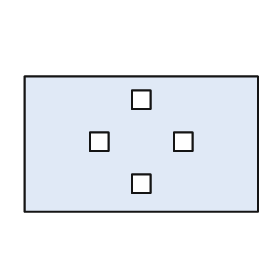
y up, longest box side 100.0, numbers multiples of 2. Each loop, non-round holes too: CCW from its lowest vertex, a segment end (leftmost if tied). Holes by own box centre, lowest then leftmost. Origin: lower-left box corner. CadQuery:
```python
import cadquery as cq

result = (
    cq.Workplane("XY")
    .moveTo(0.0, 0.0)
    .lineTo(100.0, 0.0)
    .lineTo(100.0, 58.0)
    .lineTo(0.0, 58.0)
    .close()
    .moveTo(46.0, 8.0)
    .lineTo(54.0, 8.0)
    .lineTo(54.0, 16.0)
    .lineTo(46.0, 16.0)
    .close()
    .moveTo(28.0, 26.0)
    .lineTo(36.0, 26.0)
    .lineTo(36.0, 34.0)
    .lineTo(28.0, 34.0)
    .close()
    .moveTo(64.0, 26.0)
    .lineTo(72.0, 26.0)
    .lineTo(72.0, 34.0)
    .lineTo(64.0, 34.0)
    .close()
    .moveTo(46.0, 44.0)
    .lineTo(54.0, 44.0)
    .lineTo(54.0, 52.0)
    .lineTo(46.0, 52.0)
    .close()
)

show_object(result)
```